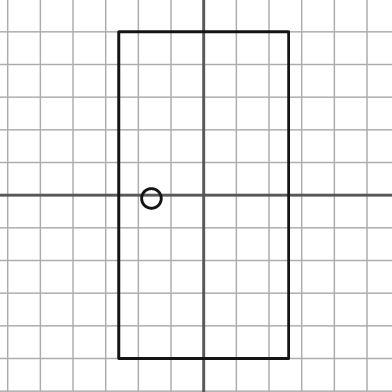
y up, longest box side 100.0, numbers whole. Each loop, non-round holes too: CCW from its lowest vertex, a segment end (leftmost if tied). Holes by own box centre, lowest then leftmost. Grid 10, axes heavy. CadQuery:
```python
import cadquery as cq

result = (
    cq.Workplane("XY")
    .moveTo(-26.0, -50.0)
    .lineTo(26.0, -50.0)
    .lineTo(26.0, 50.0)
    .lineTo(-26.0, 50.0)
    .close()
    .moveTo(-16.0, -1.0)
    .circle(3.0)
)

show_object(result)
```